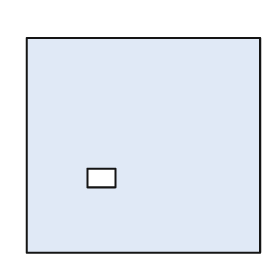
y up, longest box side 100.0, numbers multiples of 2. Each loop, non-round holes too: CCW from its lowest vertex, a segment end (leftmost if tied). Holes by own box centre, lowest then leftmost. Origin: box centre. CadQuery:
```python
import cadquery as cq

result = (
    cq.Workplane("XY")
    .moveTo(-50.0, -46.0)
    .lineTo(50.0, -46.0)
    .lineTo(50.0, 46.0)
    .lineTo(-50.0, 46.0)
    .close()
    .moveTo(-24.0, -18.0)
    .lineTo(-12.0, -18.0)
    .lineTo(-12.0, -10.0)
    .lineTo(-24.0, -10.0)
    .close()
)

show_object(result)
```